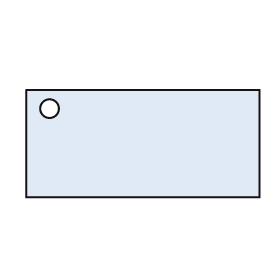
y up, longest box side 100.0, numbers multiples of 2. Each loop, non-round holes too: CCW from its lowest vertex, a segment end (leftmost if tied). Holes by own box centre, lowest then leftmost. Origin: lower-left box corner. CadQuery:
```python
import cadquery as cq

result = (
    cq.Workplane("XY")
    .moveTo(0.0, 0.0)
    .lineTo(100.0, 0.0)
    .lineTo(100.0, 46.0)
    .lineTo(0.0, 46.0)
    .close()
    .moveTo(10.0, 38.0)
    .circle(4.0)
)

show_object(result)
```